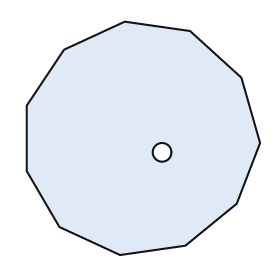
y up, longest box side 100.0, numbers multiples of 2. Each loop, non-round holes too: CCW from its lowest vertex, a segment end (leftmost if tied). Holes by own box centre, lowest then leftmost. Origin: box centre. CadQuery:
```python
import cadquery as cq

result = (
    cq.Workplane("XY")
    .moveTo(-10.0, -50.0)
    .lineTo(18.0, -46.0)
    .lineTo(40.0, -28.0)
    .lineTo(50.0, -2.0)
    .lineTo(42.0, 26.0)
    .lineTo(20.0, 46.0)
    .lineTo(-8.0, 50.0)
    .lineTo(-34.0, 38.0)
    .lineTo(-50.0, 14.0)
    .lineTo(-50.0, -14.0)
    .lineTo(-36.0, -38.0)
    .close()
    .moveTo(8.0, -6.0)
    .circle(4.0)
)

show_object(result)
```